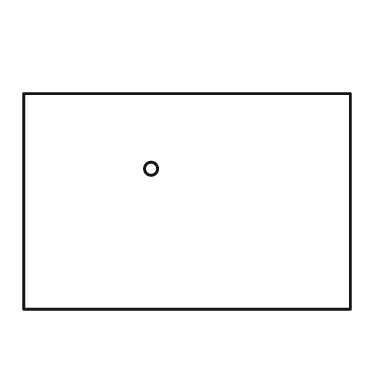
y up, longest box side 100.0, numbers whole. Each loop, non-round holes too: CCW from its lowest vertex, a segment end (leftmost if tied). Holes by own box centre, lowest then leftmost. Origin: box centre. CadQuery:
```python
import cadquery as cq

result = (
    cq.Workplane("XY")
    .moveTo(-50.0, -33.0)
    .lineTo(50.0, -33.0)
    .lineTo(50.0, 33.0)
    .lineTo(-50.0, 33.0)
    .close()
    .moveTo(-11.0, 10.0)
    .circle(2.0)
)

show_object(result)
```